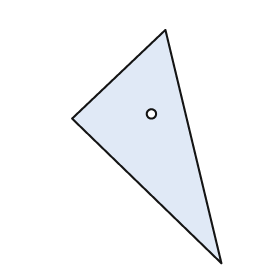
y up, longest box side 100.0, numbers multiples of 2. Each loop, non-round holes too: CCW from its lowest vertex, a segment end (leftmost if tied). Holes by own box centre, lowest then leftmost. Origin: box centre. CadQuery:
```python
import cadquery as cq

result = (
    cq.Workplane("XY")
    .moveTo(32.0, -50.0)
    .lineTo(8.0, 50.0)
    .lineTo(-32.0, 12.0)
    .close()
    .moveTo(2.0, 14.0)
    .circle(2.0)
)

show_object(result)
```